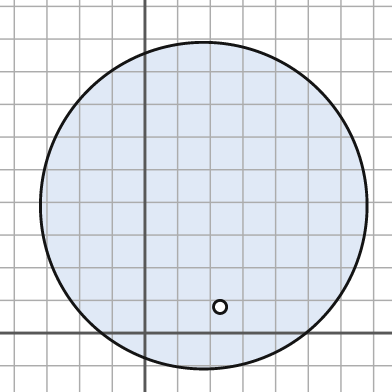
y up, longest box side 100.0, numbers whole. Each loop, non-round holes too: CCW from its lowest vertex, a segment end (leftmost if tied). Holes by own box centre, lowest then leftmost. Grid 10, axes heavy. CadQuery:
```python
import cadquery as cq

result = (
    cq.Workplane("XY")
    .moveTo(18.0, 39.0)
    .circle(50.0)
    .moveTo(23.0, 8.0)
    .circle(2.0)
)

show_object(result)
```